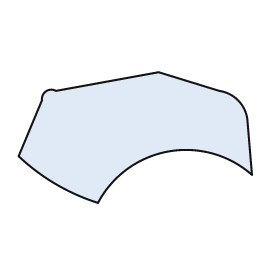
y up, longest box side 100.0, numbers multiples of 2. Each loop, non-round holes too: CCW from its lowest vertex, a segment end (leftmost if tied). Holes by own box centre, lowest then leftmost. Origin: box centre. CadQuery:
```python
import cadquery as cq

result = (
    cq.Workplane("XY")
    .moveTo(-16.0, -28.0)
    .threePointArc((14.0, -6.0), (50.0, -16.0))
    .lineTo(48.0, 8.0)
    .threePointArc((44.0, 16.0), (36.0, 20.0))
    .lineTo(10.0, 28.0)
    .lineTo(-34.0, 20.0)
    .threePointArc((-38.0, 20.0), (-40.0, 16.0))
    .lineTo(-50.0, -8.0)
    .threePointArc((-34.0, -20.0), (-16.0, -28.0))
    .close()
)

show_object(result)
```